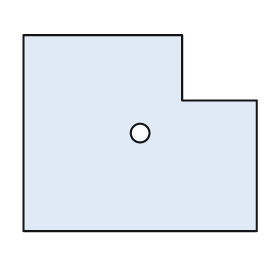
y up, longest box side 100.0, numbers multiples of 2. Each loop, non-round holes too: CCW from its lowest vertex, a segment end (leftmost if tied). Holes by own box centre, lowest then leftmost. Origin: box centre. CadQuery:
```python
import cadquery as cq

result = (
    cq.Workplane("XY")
    .moveTo(-50.0, -42.0)
    .lineTo(50.0, -42.0)
    .lineTo(50.0, 14.0)
    .lineTo(18.0, 14.0)
    .lineTo(18.0, 42.0)
    .lineTo(-50.0, 42.0)
    .close()
    .moveTo(0.0, 0.0)
    .circle(4.0)
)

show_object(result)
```